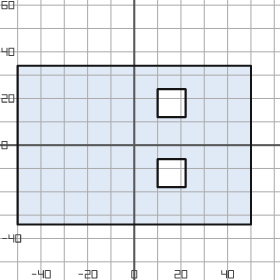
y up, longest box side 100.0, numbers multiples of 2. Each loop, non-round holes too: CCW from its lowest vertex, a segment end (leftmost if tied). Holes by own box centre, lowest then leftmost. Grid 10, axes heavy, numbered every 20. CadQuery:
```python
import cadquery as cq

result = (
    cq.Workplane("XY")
    .moveTo(-50.0, -34.0)
    .lineTo(50.0, -34.0)
    .lineTo(50.0, 34.0)
    .lineTo(-50.0, 34.0)
    .close()
    .moveTo(10.0, -18.0)
    .lineTo(22.0, -18.0)
    .lineTo(22.0, -6.0)
    .lineTo(10.0, -6.0)
    .close()
    .moveTo(10.0, 12.0)
    .lineTo(22.0, 12.0)
    .lineTo(22.0, 24.0)
    .lineTo(10.0, 24.0)
    .close()
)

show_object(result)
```